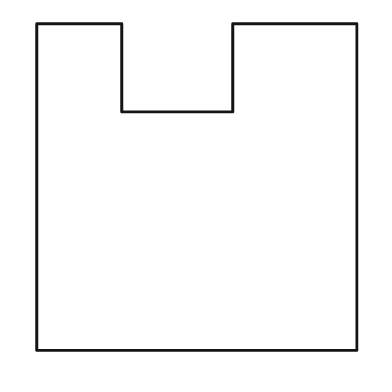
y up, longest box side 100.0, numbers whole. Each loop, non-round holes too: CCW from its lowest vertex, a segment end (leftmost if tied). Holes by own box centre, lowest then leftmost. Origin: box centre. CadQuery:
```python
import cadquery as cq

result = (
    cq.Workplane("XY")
    .moveTo(-49.0, -50.0)
    .lineTo(49.0, -50.0)
    .lineTo(49.0, 50.0)
    .lineTo(11.0, 50.0)
    .lineTo(11.0, 23.0)
    .lineTo(-23.0, 23.0)
    .lineTo(-23.0, 50.0)
    .lineTo(-49.0, 50.0)
    .close()
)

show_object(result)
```